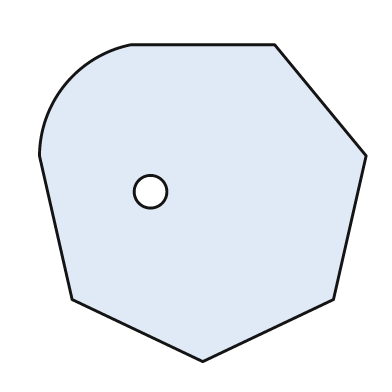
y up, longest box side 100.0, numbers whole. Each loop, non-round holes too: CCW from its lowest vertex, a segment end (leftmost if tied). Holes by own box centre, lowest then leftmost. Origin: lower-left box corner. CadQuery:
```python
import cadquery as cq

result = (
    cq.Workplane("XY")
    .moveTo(50.0, 0.0)
    .lineTo(90.0, 19.0)
    .lineTo(100.0, 63.0)
    .lineTo(72.0, 97.0)
    .lineTo(28.0, 97.0)
    .threePointArc((8.0, 85.0), (0.0, 63.0))
    .lineTo(10.0, 19.0)
    .close()
    .moveTo(34.0, 52.0)
    .circle(5.0)
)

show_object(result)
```